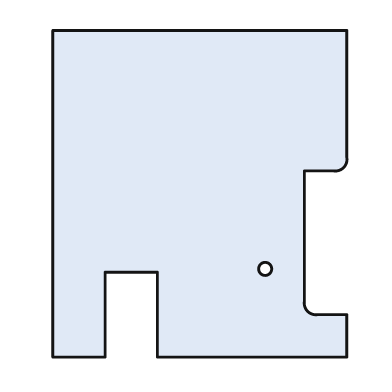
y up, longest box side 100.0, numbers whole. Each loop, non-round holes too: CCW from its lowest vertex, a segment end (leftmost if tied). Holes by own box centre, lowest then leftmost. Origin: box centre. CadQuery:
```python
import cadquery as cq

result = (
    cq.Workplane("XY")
    .moveTo(-45.0, -50.0)
    .lineTo(-29.0, -50.0)
    .lineTo(-29.0, -24.0)
    .lineTo(-13.0, -24.0)
    .lineTo(-13.0, -50.0)
    .lineTo(45.0, -50.0)
    .lineTo(45.0, -37.0)
    .lineTo(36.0, -37.0)
    .threePointArc((33.0, -36.0), (32.0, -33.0))
    .lineTo(32.0, 7.0)
    .lineTo(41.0, 7.0)
    .threePointArc((44.0, 8.0), (45.0, 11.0))
    .lineTo(45.0, 50.0)
    .lineTo(-45.0, 50.0)
    .close()
    .moveTo(20.0, -23.0)
    .circle(2.0)
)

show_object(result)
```